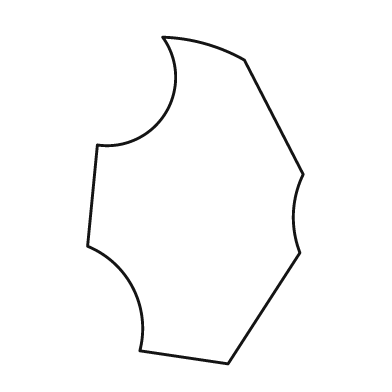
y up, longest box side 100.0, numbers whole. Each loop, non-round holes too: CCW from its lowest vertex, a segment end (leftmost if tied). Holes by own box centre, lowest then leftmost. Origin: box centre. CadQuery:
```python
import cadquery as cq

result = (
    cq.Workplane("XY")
    .moveTo(10.0, -50.0)
    .lineTo(32.0, -16.0)
    .threePointArc((30.0, -4.0), (33.0, 8.0))
    .lineTo(15.0, 43.0)
    .threePointArc((3.0, 48.0), (-10.0, 50.0))
    .threePointArc((-9.0, 27.0), (-30.0, 17.0))
    .lineTo(-33.0, -14.0)
    .threePointArc((-19.0, -27.0), (-17.0, -46.0))
    .close()
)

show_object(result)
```